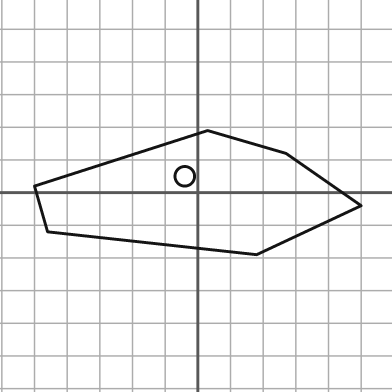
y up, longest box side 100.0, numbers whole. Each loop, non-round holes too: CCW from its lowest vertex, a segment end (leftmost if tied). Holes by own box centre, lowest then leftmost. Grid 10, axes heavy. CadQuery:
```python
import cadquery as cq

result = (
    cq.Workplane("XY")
    .moveTo(18.0, -19.0)
    .lineTo(50.0, -4.0)
    .lineTo(27.0, 12.0)
    .lineTo(3.0, 19.0)
    .lineTo(-50.0, 2.0)
    .lineTo(-46.0, -12.0)
    .close()
    .moveTo(-4.0, 5.0)
    .circle(3.0)
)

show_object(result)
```